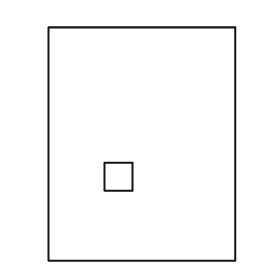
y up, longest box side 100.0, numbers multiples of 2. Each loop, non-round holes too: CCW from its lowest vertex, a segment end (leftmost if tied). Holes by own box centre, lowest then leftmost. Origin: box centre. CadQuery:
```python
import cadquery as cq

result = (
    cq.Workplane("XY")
    .moveTo(-40.0, -50.0)
    .lineTo(40.0, -50.0)
    .lineTo(40.0, 50.0)
    .lineTo(-40.0, 50.0)
    .close()
    .moveTo(-16.0, -20.0)
    .lineTo(-4.0, -20.0)
    .lineTo(-4.0, -8.0)
    .lineTo(-16.0, -8.0)
    .close()
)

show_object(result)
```